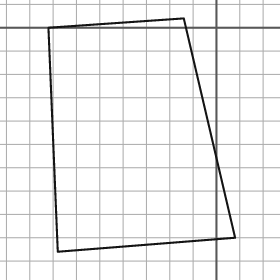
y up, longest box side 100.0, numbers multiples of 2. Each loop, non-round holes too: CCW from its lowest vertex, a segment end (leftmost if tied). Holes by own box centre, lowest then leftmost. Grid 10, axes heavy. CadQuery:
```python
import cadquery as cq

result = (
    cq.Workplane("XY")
    .moveTo(-68.0, -96.0)
    .lineTo(8.0, -90.0)
    .lineTo(-14.0, 4.0)
    .lineTo(-72.0, 0.0)
    .close()
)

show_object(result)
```